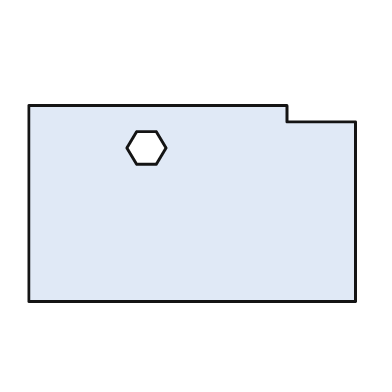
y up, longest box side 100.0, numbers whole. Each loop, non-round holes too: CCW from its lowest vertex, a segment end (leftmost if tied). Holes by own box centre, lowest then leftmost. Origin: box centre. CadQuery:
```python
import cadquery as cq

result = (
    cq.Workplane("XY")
    .moveTo(-50.0, -30.0)
    .lineTo(50.0, -30.0)
    .lineTo(50.0, 25.0)
    .lineTo(29.0, 25.0)
    .lineTo(29.0, 30.0)
    .lineTo(-50.0, 30.0)
    .close()
    .moveTo(-17.0, 12.0)
    .lineTo(-11.0, 12.0)
    .lineTo(-8.0, 17.0)
    .lineTo(-11.0, 22.0)
    .lineTo(-17.0, 22.0)
    .lineTo(-20.0, 17.0)
    .close()
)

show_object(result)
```